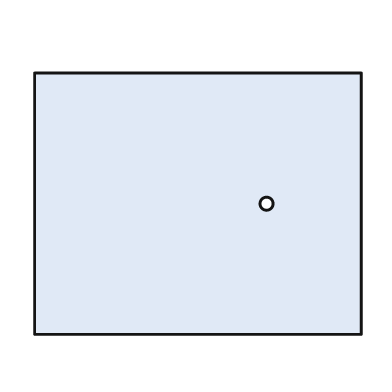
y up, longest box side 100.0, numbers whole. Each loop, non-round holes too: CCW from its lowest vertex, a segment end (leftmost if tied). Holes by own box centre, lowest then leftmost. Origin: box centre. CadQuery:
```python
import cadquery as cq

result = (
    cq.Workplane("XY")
    .moveTo(-50.0, -40.0)
    .lineTo(50.0, -40.0)
    .lineTo(50.0, 40.0)
    .lineTo(-50.0, 40.0)
    .close()
    .moveTo(21.0, 0.0)
    .circle(2.0)
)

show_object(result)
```